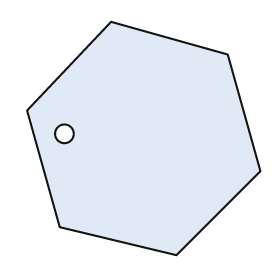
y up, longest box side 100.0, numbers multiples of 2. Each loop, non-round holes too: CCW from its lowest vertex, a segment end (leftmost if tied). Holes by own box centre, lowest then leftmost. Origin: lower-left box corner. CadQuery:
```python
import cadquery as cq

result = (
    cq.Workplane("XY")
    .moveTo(64.0, 0.0)
    .lineTo(100.0, 36.0)
    .lineTo(86.0, 86.0)
    .lineTo(36.0, 100.0)
    .lineTo(0.0, 62.0)
    .lineTo(14.0, 12.0)
    .close()
    .moveTo(16.0, 52.0)
    .circle(4.0)
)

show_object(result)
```